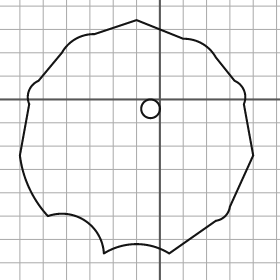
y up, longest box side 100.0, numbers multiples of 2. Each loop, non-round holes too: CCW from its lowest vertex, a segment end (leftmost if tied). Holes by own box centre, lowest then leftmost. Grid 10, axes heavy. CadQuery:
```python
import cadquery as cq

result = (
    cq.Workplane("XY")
    .moveTo(-24.0, -66.0)
    .threePointArc((-10.0, -62.0), (4.0, -66.0))
    .lineTo(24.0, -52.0)
    .threePointArc((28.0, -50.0), (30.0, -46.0))
    .lineTo(40.0, -24.0)
    .lineTo(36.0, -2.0)
    .threePointArc((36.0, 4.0), (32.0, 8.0))
    .lineTo(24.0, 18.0)
    .threePointArc((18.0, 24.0), (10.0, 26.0))
    .lineTo(-10.0, 34.0)
    .lineTo(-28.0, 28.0)
    .threePointArc((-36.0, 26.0), (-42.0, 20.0))
    .lineTo(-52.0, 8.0)
    .threePointArc((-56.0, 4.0), (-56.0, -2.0))
    .lineTo(-60.0, -24.0)
    .threePointArc((-56.0, -38.0), (-48.0, -50.0))
    .threePointArc((-32.0, -52.0), (-24.0, -66.0))
    .close()
    .moveTo(-4.0, -4.0)
    .circle(4.0)
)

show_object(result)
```